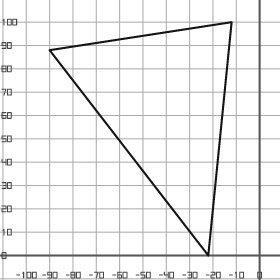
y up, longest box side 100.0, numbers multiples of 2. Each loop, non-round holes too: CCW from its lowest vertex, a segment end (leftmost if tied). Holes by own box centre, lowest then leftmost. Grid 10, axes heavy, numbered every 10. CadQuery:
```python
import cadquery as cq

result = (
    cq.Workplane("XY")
    .moveTo(-22.0, 0.0)
    .lineTo(-12.0, 100.0)
    .lineTo(-90.0, 88.0)
    .close()
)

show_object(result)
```